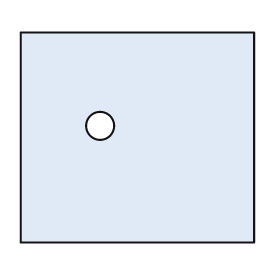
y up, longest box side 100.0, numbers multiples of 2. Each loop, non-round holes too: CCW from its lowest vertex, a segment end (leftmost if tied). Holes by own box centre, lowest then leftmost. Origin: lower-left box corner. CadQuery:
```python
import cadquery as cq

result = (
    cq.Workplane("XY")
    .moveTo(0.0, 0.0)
    .lineTo(100.0, 0.0)
    .lineTo(100.0, 90.0)
    .lineTo(0.0, 90.0)
    .close()
    .moveTo(34.0, 50.0)
    .circle(6.0)
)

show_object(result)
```